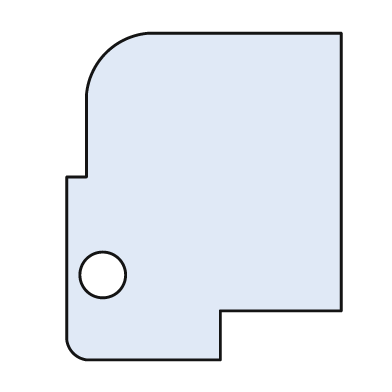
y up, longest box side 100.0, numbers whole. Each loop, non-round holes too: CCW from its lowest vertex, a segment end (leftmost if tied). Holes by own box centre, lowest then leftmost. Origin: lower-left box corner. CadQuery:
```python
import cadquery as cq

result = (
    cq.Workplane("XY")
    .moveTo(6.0, 0.0)
    .lineTo(47.0, 0.0)
    .lineTo(47.0, 15.0)
    .lineTo(84.0, 15.0)
    .lineTo(84.0, 100.0)
    .lineTo(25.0, 100.0)
    .threePointArc((12.0, 94.0), (6.0, 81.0))
    .lineTo(6.0, 56.0)
    .lineTo(0.0, 56.0)
    .lineTo(0.0, 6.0)
    .threePointArc((2.0, 2.0), (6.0, 0.0))
    .close()
    .moveTo(11.0, 26.0)
    .circle(7.0)
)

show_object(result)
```